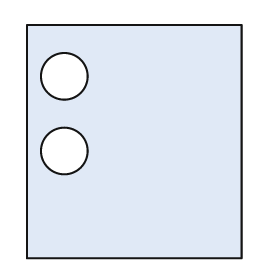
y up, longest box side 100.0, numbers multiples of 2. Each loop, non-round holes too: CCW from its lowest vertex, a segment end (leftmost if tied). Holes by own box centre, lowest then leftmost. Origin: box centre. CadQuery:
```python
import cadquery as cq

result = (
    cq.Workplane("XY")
    .moveTo(-46.0, -50.0)
    .lineTo(46.0, -50.0)
    .lineTo(46.0, 50.0)
    .lineTo(-46.0, 50.0)
    .close()
    .moveTo(-30.0, -4.0)
    .circle(10.0)
    .moveTo(-30.0, 28.0)
    .circle(10.0)
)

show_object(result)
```